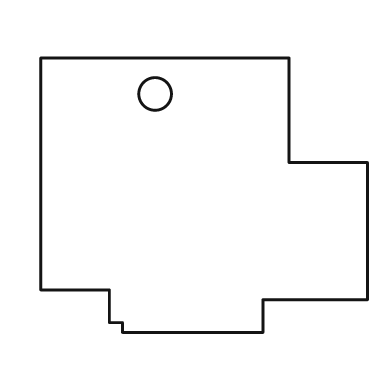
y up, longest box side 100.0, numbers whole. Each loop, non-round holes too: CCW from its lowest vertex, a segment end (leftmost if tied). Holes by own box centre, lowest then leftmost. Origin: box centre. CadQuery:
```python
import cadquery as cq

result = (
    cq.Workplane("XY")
    .moveTo(-25.0, -42.0)
    .lineTo(18.0, -42.0)
    .lineTo(18.0, -32.0)
    .lineTo(50.0, -32.0)
    .lineTo(50.0, 10.0)
    .lineTo(26.0, 10.0)
    .lineTo(26.0, 42.0)
    .lineTo(-50.0, 42.0)
    .lineTo(-50.0, -29.0)
    .lineTo(-29.0, -29.0)
    .lineTo(-29.0, -39.0)
    .lineTo(-25.0, -39.0)
    .close()
    .moveTo(-15.0, 31.0)
    .circle(5.0)
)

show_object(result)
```